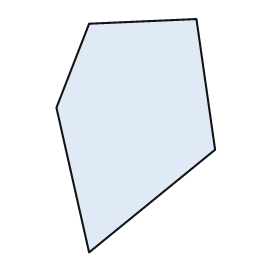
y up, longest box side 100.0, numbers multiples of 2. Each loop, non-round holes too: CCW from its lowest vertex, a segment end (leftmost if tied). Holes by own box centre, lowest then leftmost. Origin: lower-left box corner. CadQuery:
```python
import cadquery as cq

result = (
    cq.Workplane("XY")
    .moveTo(14.0, 0.0)
    .lineTo(68.0, 44.0)
    .lineTo(60.0, 100.0)
    .lineTo(14.0, 98.0)
    .lineTo(0.0, 62.0)
    .close()
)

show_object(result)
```